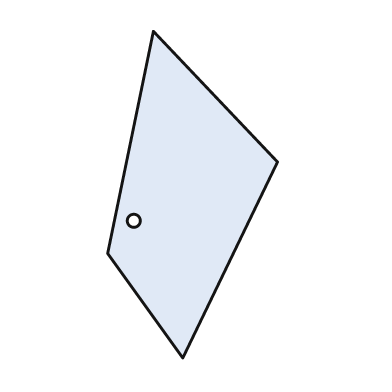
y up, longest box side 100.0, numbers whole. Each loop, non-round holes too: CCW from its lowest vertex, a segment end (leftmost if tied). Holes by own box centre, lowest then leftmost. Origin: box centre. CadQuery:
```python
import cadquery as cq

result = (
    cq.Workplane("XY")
    .moveTo(-3.0, -50.0)
    .lineTo(26.0, 10.0)
    .lineTo(-12.0, 50.0)
    .lineTo(-26.0, -18.0)
    .close()
    .moveTo(-18.0, -8.0)
    .circle(2.0)
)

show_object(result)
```